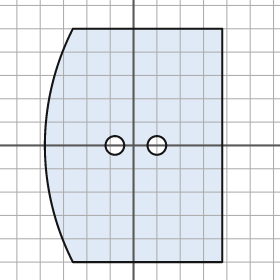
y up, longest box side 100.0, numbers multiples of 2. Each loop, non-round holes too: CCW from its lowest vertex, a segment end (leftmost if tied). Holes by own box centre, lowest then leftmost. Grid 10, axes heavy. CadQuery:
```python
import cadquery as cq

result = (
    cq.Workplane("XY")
    .moveTo(-26.0, -50.0)
    .lineTo(38.0, -50.0)
    .lineTo(38.0, 50.0)
    .lineTo(-26.0, 50.0)
    .threePointArc((-38.0, 0.0), (-26.0, -50.0))
    .close()
    .moveTo(-8.0, 0.0)
    .circle(4.0)
    .moveTo(10.0, 0.0)
    .circle(4.0)
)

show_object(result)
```